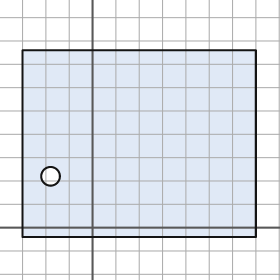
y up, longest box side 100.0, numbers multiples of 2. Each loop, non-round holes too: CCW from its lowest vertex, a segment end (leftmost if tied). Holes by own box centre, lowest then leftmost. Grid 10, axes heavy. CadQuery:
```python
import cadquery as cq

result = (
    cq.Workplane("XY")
    .moveTo(-30.0, -4.0)
    .lineTo(70.0, -4.0)
    .lineTo(70.0, 76.0)
    .lineTo(-30.0, 76.0)
    .close()
    .moveTo(-18.0, 22.0)
    .circle(4.0)
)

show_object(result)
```